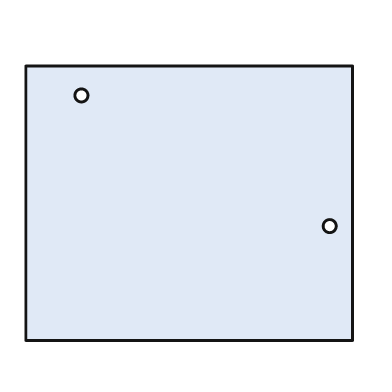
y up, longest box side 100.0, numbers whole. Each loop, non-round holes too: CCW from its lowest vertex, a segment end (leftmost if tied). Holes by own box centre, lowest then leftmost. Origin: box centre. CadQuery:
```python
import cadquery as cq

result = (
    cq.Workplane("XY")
    .moveTo(-50.0, -42.0)
    .lineTo(50.0, -42.0)
    .lineTo(50.0, 42.0)
    .lineTo(-50.0, 42.0)
    .close()
    .moveTo(43.0, -7.0)
    .circle(2.0)
    .moveTo(-33.0, 33.0)
    .circle(2.0)
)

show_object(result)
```